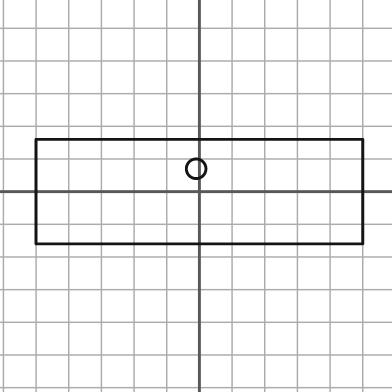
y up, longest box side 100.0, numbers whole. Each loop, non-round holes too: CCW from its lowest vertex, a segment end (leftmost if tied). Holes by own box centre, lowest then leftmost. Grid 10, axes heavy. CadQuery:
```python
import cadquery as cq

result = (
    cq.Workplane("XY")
    .moveTo(-50.0, -16.0)
    .lineTo(50.0, -16.0)
    .lineTo(50.0, 16.0)
    .lineTo(-50.0, 16.0)
    .close()
    .moveTo(-1.0, 7.0)
    .circle(3.0)
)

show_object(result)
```